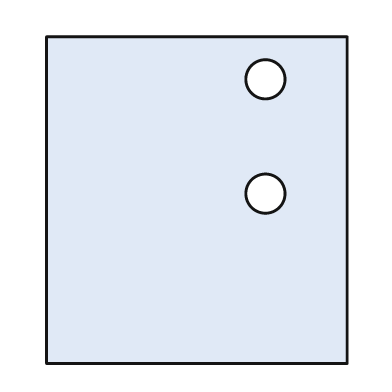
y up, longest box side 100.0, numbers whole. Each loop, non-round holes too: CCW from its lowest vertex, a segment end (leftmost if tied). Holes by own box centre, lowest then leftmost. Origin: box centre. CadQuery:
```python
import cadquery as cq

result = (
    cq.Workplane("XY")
    .moveTo(-46.0, -50.0)
    .lineTo(46.0, -50.0)
    .lineTo(46.0, 50.0)
    .lineTo(-46.0, 50.0)
    .close()
    .moveTo(21.0, 2.0)
    .circle(6.0)
    .moveTo(21.0, 37.0)
    .circle(6.0)
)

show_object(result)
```